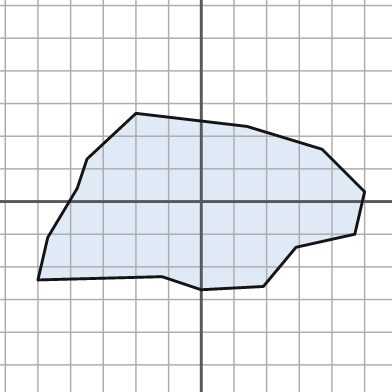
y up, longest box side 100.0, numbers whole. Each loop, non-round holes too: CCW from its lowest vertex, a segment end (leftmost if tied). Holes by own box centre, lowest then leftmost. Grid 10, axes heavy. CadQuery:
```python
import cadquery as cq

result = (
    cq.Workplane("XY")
    .moveTo(0.0, -27.0)
    .lineTo(19.0, -26.0)
    .lineTo(29.0, -14.0)
    .lineTo(47.0, -10.0)
    .lineTo(50.0, 3.0)
    .lineTo(37.0, 16.0)
    .lineTo(14.0, 23.0)
    .lineTo(-20.0, 27.0)
    .lineTo(-35.0, 13.0)
    .lineTo(-38.0, 4.0)
    .lineTo(-47.0, -11.0)
    .lineTo(-50.0, -24.0)
    .lineTo(-12.0, -23.0)
    .close()
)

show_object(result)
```